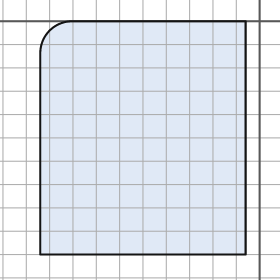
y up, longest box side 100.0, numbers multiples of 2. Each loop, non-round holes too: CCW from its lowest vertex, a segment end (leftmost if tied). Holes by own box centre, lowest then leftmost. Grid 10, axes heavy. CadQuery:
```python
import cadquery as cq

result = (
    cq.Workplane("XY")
    .moveTo(-94.0, -100.0)
    .lineTo(-6.0, -100.0)
    .lineTo(-6.0, 0.0)
    .lineTo(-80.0, 0.0)
    .threePointArc((-90.0, -4.0), (-94.0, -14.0))
    .close()
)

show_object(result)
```